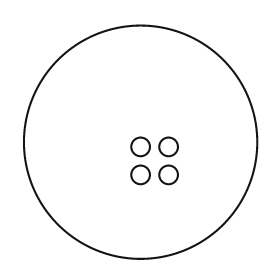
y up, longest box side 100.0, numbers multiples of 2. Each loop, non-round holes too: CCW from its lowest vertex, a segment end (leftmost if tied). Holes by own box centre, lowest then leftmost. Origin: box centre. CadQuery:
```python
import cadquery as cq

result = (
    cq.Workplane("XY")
    .moveTo(0.0, 0.0)
    .circle(50.0)
    .moveTo(0.0, -14.0)
    .circle(4.0)
    .moveTo(12.0, -14.0)
    .circle(4.0)
    .moveTo(0.0, -2.0)
    .circle(4.0)
    .moveTo(12.0, -2.0)
    .circle(4.0)
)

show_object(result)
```